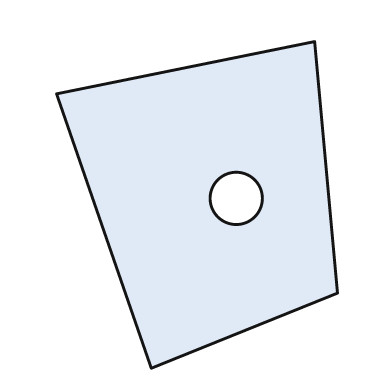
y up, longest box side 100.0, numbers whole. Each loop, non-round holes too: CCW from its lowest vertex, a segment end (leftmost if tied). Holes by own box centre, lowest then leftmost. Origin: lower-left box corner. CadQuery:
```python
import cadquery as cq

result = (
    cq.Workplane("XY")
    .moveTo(29.0, 0.0)
    .lineTo(86.0, 23.0)
    .lineTo(79.0, 100.0)
    .lineTo(0.0, 84.0)
    .close()
    .moveTo(55.0, 52.0)
    .circle(8.0)
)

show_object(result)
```